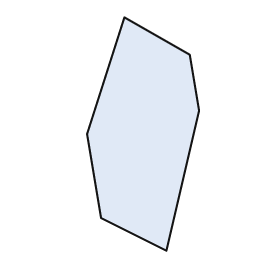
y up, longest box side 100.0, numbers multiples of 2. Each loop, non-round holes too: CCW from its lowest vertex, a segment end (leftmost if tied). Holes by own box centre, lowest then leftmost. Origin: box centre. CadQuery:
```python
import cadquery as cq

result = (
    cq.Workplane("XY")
    .moveTo(10.0, -50.0)
    .lineTo(24.0, 10.0)
    .lineTo(20.0, 34.0)
    .lineTo(-8.0, 50.0)
    .lineTo(-24.0, 0.0)
    .lineTo(-18.0, -36.0)
    .close()
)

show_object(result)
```